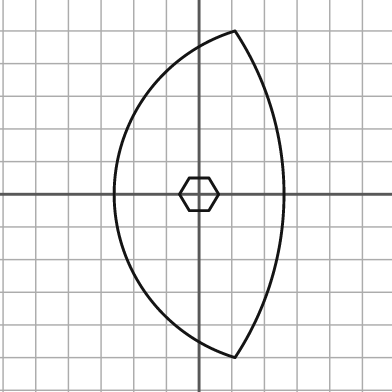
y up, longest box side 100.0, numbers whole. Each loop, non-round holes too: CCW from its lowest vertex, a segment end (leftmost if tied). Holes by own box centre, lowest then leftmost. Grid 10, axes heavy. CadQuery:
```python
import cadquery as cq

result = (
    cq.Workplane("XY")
    .moveTo(11.0, -50.0)
    .threePointArc((26.0, 0.0), (11.0, 50.0))
    .threePointArc((-26.0, 0.0), (11.0, -50.0))
    .close()
    .moveTo(-3.0, -5.0)
    .lineTo(3.0, -5.0)
    .lineTo(6.0, 0.0)
    .lineTo(3.0, 5.0)
    .lineTo(-3.0, 5.0)
    .lineTo(-6.0, 0.0)
    .close()
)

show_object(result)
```